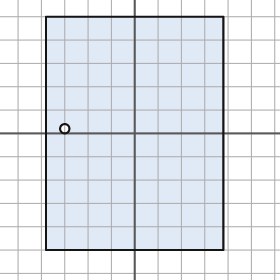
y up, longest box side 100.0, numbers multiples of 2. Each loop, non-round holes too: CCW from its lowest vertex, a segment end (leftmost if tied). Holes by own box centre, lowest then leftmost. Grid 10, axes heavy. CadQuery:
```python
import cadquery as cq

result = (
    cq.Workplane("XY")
    .moveTo(-38.0, -50.0)
    .lineTo(38.0, -50.0)
    .lineTo(38.0, 50.0)
    .lineTo(-38.0, 50.0)
    .close()
    .moveTo(-30.0, 2.0)
    .circle(2.0)
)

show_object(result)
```